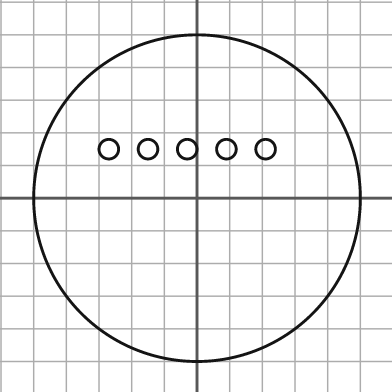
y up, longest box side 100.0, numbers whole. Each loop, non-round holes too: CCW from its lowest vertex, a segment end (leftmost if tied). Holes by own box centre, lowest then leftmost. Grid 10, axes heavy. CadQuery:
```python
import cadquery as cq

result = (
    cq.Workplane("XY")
    .moveTo(0.0, 0.0)
    .circle(50.0)
    .moveTo(-27.0, 15.0)
    .circle(3.0)
    .moveTo(-15.0, 15.0)
    .circle(3.0)
    .moveTo(-3.0, 15.0)
    .circle(3.0)
    .moveTo(9.0, 15.0)
    .circle(3.0)
    .moveTo(21.0, 15.0)
    .circle(3.0)
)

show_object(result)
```